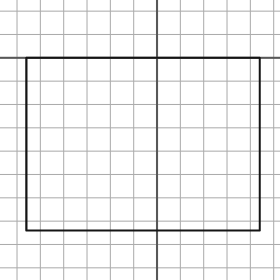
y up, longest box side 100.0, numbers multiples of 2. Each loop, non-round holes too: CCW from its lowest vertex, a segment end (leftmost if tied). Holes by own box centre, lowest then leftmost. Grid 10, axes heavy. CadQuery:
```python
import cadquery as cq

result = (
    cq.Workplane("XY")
    .moveTo(-56.0, -74.0)
    .lineTo(44.0, -74.0)
    .lineTo(44.0, 0.0)
    .lineTo(-56.0, 0.0)
    .close()
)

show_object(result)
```